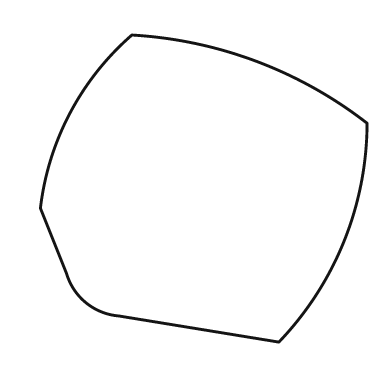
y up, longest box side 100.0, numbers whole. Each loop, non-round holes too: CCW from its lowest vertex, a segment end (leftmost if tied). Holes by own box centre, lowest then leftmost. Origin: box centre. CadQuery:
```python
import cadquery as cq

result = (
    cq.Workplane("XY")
    .moveTo(23.0, -47.0)
    .threePointArc((43.0, -16.0), (50.0, 20.0))
    .threePointArc((16.0, 39.0), (-22.0, 47.0))
    .threePointArc((-41.0, 23.0), (-50.0, -6.0))
    .lineTo(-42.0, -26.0)
    .threePointArc((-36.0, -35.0), (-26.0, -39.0))
    .close()
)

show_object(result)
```